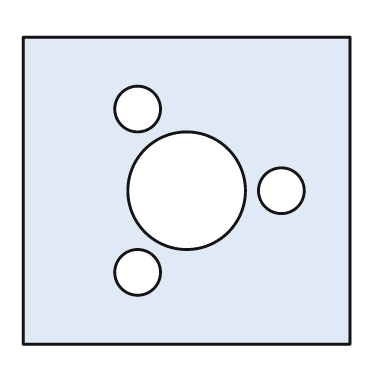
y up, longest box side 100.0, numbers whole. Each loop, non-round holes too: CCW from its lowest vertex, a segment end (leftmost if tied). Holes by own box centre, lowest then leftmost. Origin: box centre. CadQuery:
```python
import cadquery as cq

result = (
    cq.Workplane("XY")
    .moveTo(-50.0, -47.0)
    .lineTo(50.0, -47.0)
    .lineTo(50.0, 47.0)
    .lineTo(-50.0, 47.0)
    .close()
    .moveTo(-15.0, -25.0)
    .circle(7.0)
    .moveTo(0.0, 0.0)
    .circle(18.0)
    .moveTo(29.0, 0.0)
    .circle(7.0)
    .moveTo(-15.0, 25.0)
    .circle(7.0)
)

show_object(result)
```